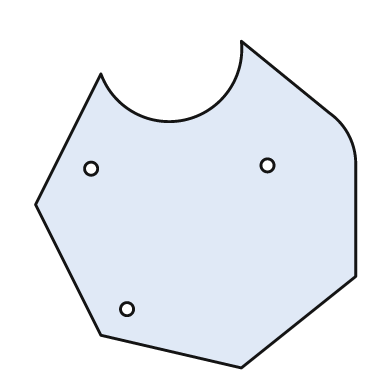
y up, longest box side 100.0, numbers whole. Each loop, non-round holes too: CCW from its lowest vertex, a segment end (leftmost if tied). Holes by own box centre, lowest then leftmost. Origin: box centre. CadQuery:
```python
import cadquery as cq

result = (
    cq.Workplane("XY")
    .moveTo(14.0, -50.0)
    .lineTo(49.0, -22.0)
    .lineTo(49.0, 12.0)
    .threePointArc((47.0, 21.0), (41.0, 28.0))
    .lineTo(14.0, 50.0)
    .threePointArc((-3.0, 26.0), (-29.0, 40.0))
    .lineTo(-49.0, 0.0)
    .lineTo(-29.0, -40.0)
    .close()
    .moveTo(-21.0, -32.0)
    .circle(2.0)
    .moveTo(-32.0, 11.0)
    .circle(2.0)
    .moveTo(22.0, 12.0)
    .circle(2.0)
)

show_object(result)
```